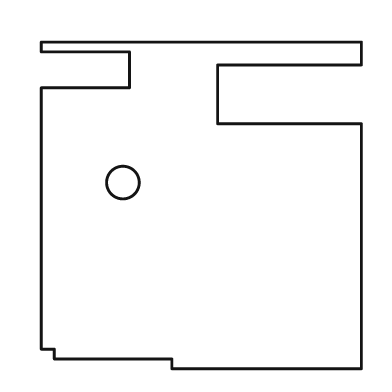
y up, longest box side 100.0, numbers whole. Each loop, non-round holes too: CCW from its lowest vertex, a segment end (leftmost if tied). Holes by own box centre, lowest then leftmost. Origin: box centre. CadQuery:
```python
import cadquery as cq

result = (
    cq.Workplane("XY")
    .moveTo(-9.0, -50.0)
    .lineTo(49.0, -50.0)
    .lineTo(49.0, 25.0)
    .lineTo(5.0, 25.0)
    .lineTo(5.0, 43.0)
    .lineTo(49.0, 43.0)
    .lineTo(49.0, 50.0)
    .lineTo(-49.0, 50.0)
    .lineTo(-49.0, 47.0)
    .lineTo(-22.0, 47.0)
    .lineTo(-22.0, 36.0)
    .lineTo(-49.0, 36.0)
    .lineTo(-49.0, -44.0)
    .lineTo(-45.0, -44.0)
    .lineTo(-45.0, -47.0)
    .lineTo(-9.0, -47.0)
    .close()
    .moveTo(-24.0, 7.0)
    .circle(5.0)
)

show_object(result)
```